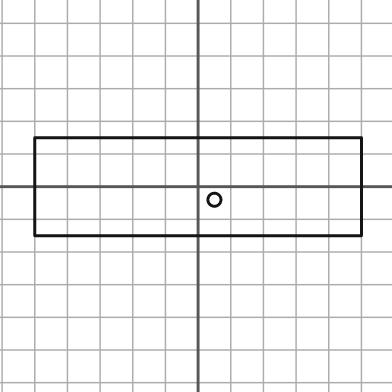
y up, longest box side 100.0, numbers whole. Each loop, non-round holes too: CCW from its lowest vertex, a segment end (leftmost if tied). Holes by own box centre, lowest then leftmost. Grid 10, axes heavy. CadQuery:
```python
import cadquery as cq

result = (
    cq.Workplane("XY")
    .moveTo(-50.0, -15.0)
    .lineTo(50.0, -15.0)
    .lineTo(50.0, 15.0)
    .lineTo(-50.0, 15.0)
    .close()
    .moveTo(5.0, -4.0)
    .circle(2.0)
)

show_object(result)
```